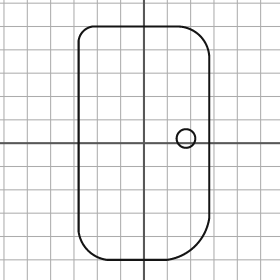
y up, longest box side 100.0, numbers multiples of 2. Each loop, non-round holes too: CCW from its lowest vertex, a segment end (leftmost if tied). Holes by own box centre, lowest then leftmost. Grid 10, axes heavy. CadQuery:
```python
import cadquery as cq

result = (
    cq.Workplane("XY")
    .moveTo(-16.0, -50.0)
    .lineTo(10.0, -50.0)
    .threePointArc((22.0, -44.0), (28.0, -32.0))
    .lineTo(28.0, 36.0)
    .threePointArc((24.0, 46.0), (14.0, 50.0))
    .lineTo(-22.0, 50.0)
    .threePointArc((-26.0, 48.0), (-28.0, 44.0))
    .lineTo(-28.0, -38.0)
    .threePointArc((-24.0, -46.0), (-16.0, -50.0))
    .close()
    .moveTo(18.0, 2.0)
    .circle(4.0)
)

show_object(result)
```